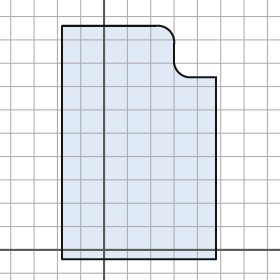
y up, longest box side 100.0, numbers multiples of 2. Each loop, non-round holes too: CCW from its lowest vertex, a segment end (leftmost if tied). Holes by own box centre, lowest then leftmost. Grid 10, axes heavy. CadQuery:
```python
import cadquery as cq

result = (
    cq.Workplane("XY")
    .moveTo(-18.0, -4.0)
    .lineTo(48.0, -4.0)
    .lineTo(48.0, 74.0)
    .lineTo(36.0, 74.0)
    .threePointArc((32.0, 76.0), (30.0, 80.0))
    .lineTo(30.0, 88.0)
    .threePointArc((28.0, 94.0), (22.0, 96.0))
    .lineTo(-18.0, 96.0)
    .close()
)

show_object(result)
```